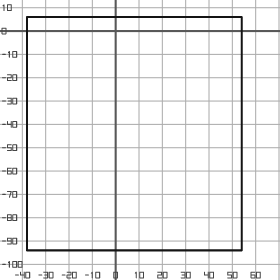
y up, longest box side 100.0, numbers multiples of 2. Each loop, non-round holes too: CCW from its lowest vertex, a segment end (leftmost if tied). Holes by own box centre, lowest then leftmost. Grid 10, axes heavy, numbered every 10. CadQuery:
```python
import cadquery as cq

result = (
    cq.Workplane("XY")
    .moveTo(-38.0, -94.0)
    .lineTo(54.0, -94.0)
    .lineTo(54.0, 6.0)
    .lineTo(-38.0, 6.0)
    .close()
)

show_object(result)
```